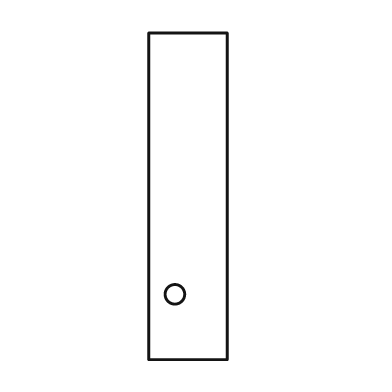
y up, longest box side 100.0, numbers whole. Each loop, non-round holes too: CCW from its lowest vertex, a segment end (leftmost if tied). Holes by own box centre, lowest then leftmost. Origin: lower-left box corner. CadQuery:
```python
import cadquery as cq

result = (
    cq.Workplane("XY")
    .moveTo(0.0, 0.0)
    .lineTo(24.0, 0.0)
    .lineTo(24.0, 100.0)
    .lineTo(0.0, 100.0)
    .close()
    .moveTo(8.0, 20.0)
    .circle(3.0)
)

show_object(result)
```